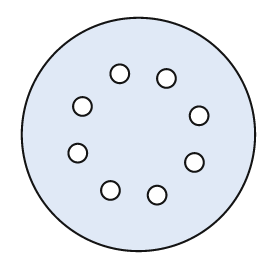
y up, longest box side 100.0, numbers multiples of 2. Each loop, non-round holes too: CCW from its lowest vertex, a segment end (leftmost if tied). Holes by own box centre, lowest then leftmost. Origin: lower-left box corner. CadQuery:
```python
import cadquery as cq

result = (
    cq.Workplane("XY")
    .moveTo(50.0, 50.0)
    .circle(50.0)
    .moveTo(58.0, 24.0)
    .circle(4.0)
    .moveTo(38.0, 26.0)
    .circle(4.0)
    .moveTo(74.0, 38.0)
    .circle(4.0)
    .moveTo(24.0, 42.0)
    .circle(4.0)
    .moveTo(76.0, 58.0)
    .circle(4.0)
    .moveTo(26.0, 62.0)
    .circle(4.0)
    .moveTo(62.0, 74.0)
    .circle(4.0)
    .moveTo(42.0, 76.0)
    .circle(4.0)
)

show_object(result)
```